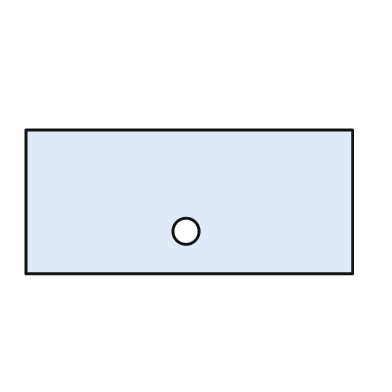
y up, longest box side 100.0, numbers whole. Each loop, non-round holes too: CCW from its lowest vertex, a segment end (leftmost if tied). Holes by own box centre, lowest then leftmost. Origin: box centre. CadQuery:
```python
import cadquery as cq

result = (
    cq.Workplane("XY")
    .moveTo(-50.0, -22.0)
    .lineTo(50.0, -22.0)
    .lineTo(50.0, 22.0)
    .lineTo(-50.0, 22.0)
    .close()
    .moveTo(-1.0, -9.0)
    .circle(4.0)
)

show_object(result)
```